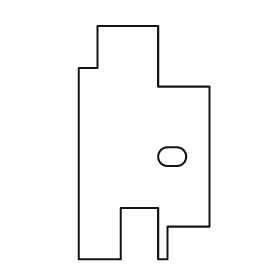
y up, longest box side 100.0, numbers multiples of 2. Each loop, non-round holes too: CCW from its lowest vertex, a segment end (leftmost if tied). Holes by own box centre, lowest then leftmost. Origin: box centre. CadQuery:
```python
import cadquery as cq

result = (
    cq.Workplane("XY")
    .moveTo(-28.0, -50.0)
    .lineTo(-10.0, -50.0)
    .lineTo(-10.0, -28.0)
    .lineTo(6.0, -28.0)
    .lineTo(6.0, -50.0)
    .lineTo(10.0, -50.0)
    .lineTo(10.0, -36.0)
    .lineTo(28.0, -36.0)
    .lineTo(28.0, 24.0)
    .lineTo(6.0, 24.0)
    .lineTo(6.0, 50.0)
    .lineTo(-20.0, 50.0)
    .lineTo(-20.0, 32.0)
    .lineTo(-28.0, 32.0)
    .close()
    .moveTo(10.0, -10.0)
    .lineTo(14.0, -10.0)
    .threePointArc((18.0, -6.0), (14.0, -2.0))
    .lineTo(10.0, -2.0)
    .threePointArc((6.0, -6.0), (10.0, -10.0))
    .close()
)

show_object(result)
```